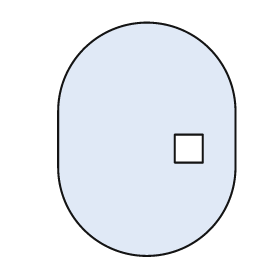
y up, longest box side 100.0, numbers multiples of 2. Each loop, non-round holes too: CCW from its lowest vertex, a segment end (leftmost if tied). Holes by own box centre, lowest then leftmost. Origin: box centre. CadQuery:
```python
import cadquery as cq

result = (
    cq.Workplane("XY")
    .moveTo(-38.0, -12.0)
    .threePointArc((0.0, -50.0), (38.0, -12.0))
    .lineTo(38.0, 12.0)
    .threePointArc((0.0, 50.0), (-38.0, 12.0))
    .close()
    .moveTo(12.0, -10.0)
    .lineTo(24.0, -10.0)
    .lineTo(24.0, 2.0)
    .lineTo(12.0, 2.0)
    .close()
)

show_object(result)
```